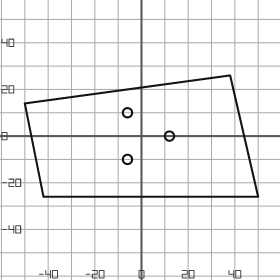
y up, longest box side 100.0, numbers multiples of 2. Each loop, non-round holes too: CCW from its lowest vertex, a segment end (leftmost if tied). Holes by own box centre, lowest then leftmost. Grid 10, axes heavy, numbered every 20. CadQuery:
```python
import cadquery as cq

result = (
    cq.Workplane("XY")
    .moveTo(-42.0, -26.0)
    .lineTo(50.0, -26.0)
    .lineTo(38.0, 26.0)
    .lineTo(-50.0, 14.0)
    .close()
    .moveTo(-6.0, -10.0)
    .circle(2.0)
    .moveTo(12.0, 0.0)
    .circle(2.0)
    .moveTo(-6.0, 10.0)
    .circle(2.0)
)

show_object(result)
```